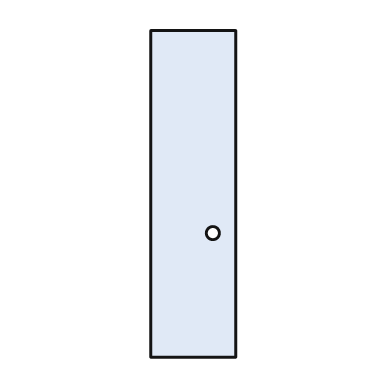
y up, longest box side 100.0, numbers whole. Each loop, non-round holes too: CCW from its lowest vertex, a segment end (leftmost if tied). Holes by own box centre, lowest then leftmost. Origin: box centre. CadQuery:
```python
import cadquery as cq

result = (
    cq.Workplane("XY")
    .moveTo(-13.0, -50.0)
    .lineTo(13.0, -50.0)
    .lineTo(13.0, 50.0)
    .lineTo(-13.0, 50.0)
    .close()
    .moveTo(6.0, -12.0)
    .circle(2.0)
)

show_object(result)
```